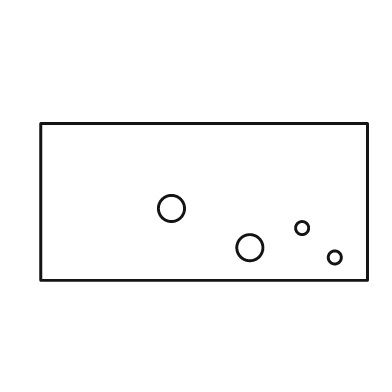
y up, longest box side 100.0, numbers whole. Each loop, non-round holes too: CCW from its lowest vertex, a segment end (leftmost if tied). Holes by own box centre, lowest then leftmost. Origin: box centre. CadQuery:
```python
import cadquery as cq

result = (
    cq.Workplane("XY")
    .moveTo(-50.0, -24.0)
    .lineTo(50.0, -24.0)
    .lineTo(50.0, 24.0)
    .lineTo(-50.0, 24.0)
    .close()
    .moveTo(40.0, -17.0)
    .circle(2.0)
    .moveTo(14.0, -14.0)
    .circle(4.0)
    .moveTo(30.0, -8.0)
    .circle(2.0)
    .moveTo(-10.0, -2.0)
    .circle(4.0)
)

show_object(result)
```